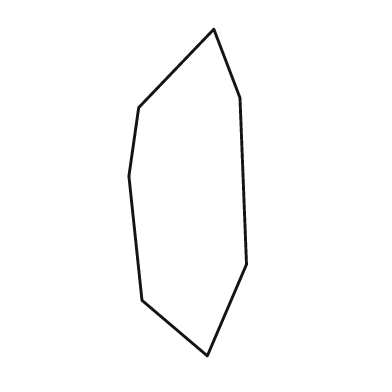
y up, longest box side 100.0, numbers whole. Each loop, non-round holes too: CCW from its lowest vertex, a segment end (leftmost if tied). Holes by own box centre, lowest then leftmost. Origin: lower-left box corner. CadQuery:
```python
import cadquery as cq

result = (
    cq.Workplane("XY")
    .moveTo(24.0, 0.0)
    .lineTo(36.0, 28.0)
    .lineTo(34.0, 79.0)
    .lineTo(26.0, 100.0)
    .lineTo(3.0, 76.0)
    .lineTo(0.0, 55.0)
    .lineTo(4.0, 17.0)
    .close()
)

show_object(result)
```